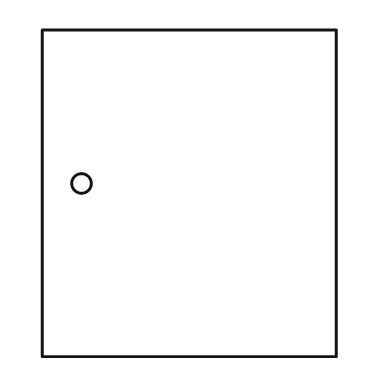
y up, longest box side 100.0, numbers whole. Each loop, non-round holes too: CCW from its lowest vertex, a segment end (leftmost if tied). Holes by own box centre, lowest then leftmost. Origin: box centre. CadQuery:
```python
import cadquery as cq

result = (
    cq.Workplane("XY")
    .moveTo(-45.0, -50.0)
    .lineTo(45.0, -50.0)
    .lineTo(45.0, 50.0)
    .lineTo(-45.0, 50.0)
    .close()
    .moveTo(-33.0, 3.0)
    .circle(3.0)
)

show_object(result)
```